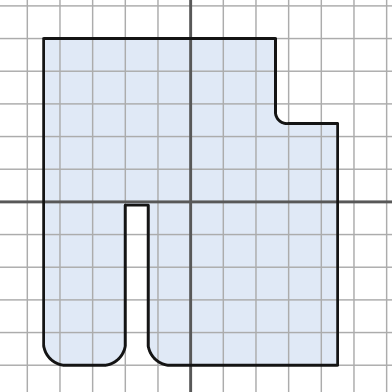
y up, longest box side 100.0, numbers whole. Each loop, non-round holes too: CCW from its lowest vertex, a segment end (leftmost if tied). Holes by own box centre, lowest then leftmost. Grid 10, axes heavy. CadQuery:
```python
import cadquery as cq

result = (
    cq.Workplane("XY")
    .moveTo(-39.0, -50.0)
    .lineTo(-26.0, -50.0)
    .threePointArc((-22.0, -48.0), (-20.0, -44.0))
    .lineTo(-20.0, -1.0)
    .lineTo(-13.0, -1.0)
    .lineTo(-13.0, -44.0)
    .threePointArc((-11.0, -48.0), (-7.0, -50.0))
    .lineTo(45.0, -50.0)
    .lineTo(45.0, 24.0)
    .lineTo(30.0, 24.0)
    .threePointArc((27.0, 25.0), (26.0, 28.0))
    .lineTo(26.0, 50.0)
    .lineTo(-45.0, 50.0)
    .lineTo(-45.0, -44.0)
    .threePointArc((-43.0, -48.0), (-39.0, -50.0))
    .close()
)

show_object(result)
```